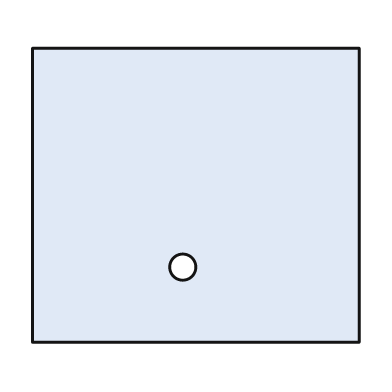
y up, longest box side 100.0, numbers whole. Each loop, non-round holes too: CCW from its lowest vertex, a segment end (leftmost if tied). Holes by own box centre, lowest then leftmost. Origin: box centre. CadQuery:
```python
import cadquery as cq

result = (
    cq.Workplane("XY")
    .moveTo(-50.0, -45.0)
    .lineTo(50.0, -45.0)
    .lineTo(50.0, 45.0)
    .lineTo(-50.0, 45.0)
    .close()
    .moveTo(-4.0, -22.0)
    .circle(4.0)
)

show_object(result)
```